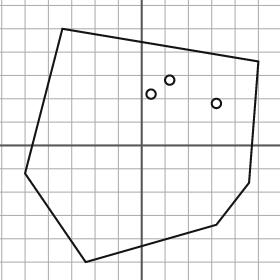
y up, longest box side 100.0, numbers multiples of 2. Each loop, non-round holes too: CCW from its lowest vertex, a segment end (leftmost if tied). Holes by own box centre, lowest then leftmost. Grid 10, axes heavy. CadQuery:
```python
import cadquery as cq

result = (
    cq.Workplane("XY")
    .moveTo(-24.0, -50.0)
    .lineTo(32.0, -34.0)
    .lineTo(46.0, -16.0)
    .lineTo(50.0, 36.0)
    .lineTo(-34.0, 50.0)
    .lineTo(-50.0, -12.0)
    .close()
    .moveTo(32.0, 18.0)
    .circle(2.0)
    .moveTo(4.0, 22.0)
    .circle(2.0)
    .moveTo(12.0, 28.0)
    .circle(2.0)
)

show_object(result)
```